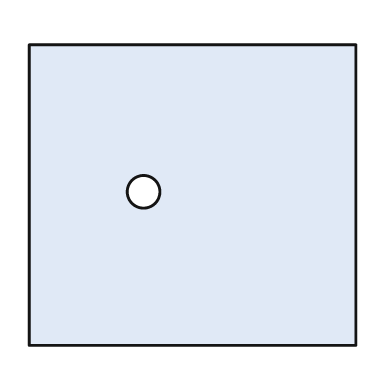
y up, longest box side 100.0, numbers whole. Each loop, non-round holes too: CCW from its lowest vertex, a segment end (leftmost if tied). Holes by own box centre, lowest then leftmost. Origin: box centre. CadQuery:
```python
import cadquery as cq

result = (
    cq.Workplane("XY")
    .moveTo(-50.0, -46.0)
    .lineTo(50.0, -46.0)
    .lineTo(50.0, 46.0)
    .lineTo(-50.0, 46.0)
    .close()
    .moveTo(-15.0, 1.0)
    .circle(5.0)
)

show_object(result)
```